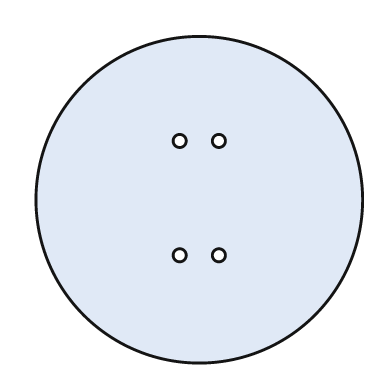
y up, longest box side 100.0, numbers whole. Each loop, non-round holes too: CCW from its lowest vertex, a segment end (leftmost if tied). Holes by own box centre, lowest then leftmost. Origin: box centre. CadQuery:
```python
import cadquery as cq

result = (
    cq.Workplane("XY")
    .moveTo(0.0, 0.0)
    .circle(50.0)
    .moveTo(-6.0, -17.0)
    .circle(2.0)
    .moveTo(6.0, -17.0)
    .circle(2.0)
    .moveTo(-6.0, 18.0)
    .circle(2.0)
    .moveTo(6.0, 18.0)
    .circle(2.0)
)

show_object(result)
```